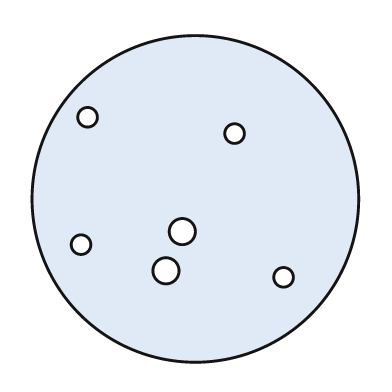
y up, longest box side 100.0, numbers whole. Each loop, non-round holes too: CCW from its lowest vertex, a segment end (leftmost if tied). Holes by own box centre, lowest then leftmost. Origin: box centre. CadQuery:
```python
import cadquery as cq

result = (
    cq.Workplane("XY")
    .moveTo(0.0, 0.0)
    .circle(50.0)
    .moveTo(27.0, -24.0)
    .circle(3.0)
    .moveTo(-9.0, -22.0)
    .circle(4.0)
    .moveTo(-35.0, -14.0)
    .circle(3.0)
    .moveTo(-4.0, -10.0)
    .circle(4.0)
    .moveTo(12.0, 20.0)
    .circle(3.0)
    .moveTo(-33.0, 25.0)
    .circle(3.0)
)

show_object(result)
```